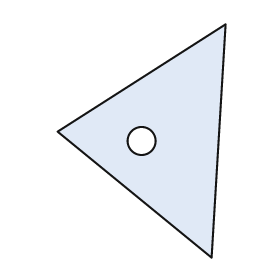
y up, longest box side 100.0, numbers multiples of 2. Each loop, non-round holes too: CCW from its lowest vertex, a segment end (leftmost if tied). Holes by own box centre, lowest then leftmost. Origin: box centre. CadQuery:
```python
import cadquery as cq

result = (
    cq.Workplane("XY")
    .moveTo(30.0, -50.0)
    .lineTo(36.0, 50.0)
    .lineTo(-36.0, 4.0)
    .close()
    .moveTo(0.0, 0.0)
    .circle(6.0)
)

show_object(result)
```